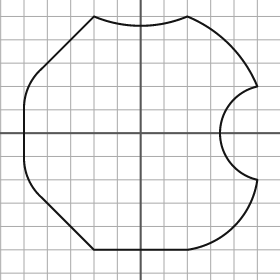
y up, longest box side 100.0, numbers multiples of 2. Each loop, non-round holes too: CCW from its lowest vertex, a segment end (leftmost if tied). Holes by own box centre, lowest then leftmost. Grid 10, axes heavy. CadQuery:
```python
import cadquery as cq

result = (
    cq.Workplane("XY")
    .moveTo(-20.0, -50.0)
    .lineTo(20.0, -50.0)
    .threePointArc((40.0, -40.0), (50.0, -20.0))
    .threePointArc((34.0, 0.0), (50.0, 20.0))
    .threePointArc((38.0, 38.0), (20.0, 50.0))
    .threePointArc((0.0, 46.0), (-20.0, 50.0))
    .lineTo(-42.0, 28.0)
    .threePointArc((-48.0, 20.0), (-50.0, 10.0))
    .lineTo(-50.0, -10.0)
    .threePointArc((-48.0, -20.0), (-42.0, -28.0))
    .close()
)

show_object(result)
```